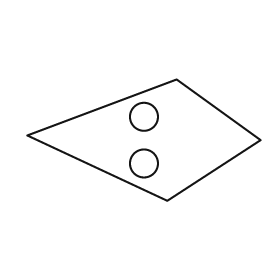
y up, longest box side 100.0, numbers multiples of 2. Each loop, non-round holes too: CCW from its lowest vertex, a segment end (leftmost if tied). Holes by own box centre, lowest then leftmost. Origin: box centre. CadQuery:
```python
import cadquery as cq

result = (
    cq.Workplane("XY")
    .moveTo(10.0, -26.0)
    .lineTo(50.0, 0.0)
    .lineTo(14.0, 26.0)
    .lineTo(-50.0, 2.0)
    .close()
    .moveTo(0.0, -10.0)
    .circle(6.0)
    .moveTo(0.0, 10.0)
    .circle(6.0)
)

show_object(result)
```